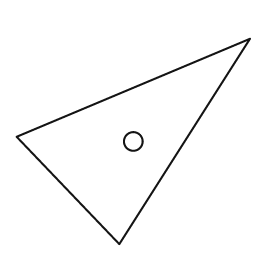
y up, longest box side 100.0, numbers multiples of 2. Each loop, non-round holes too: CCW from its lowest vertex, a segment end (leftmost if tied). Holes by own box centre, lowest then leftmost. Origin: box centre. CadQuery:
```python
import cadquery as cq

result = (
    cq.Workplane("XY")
    .moveTo(-6.0, -44.0)
    .lineTo(50.0, 44.0)
    .lineTo(-50.0, 2.0)
    .close()
    .moveTo(0.0, 0.0)
    .circle(4.0)
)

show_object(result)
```